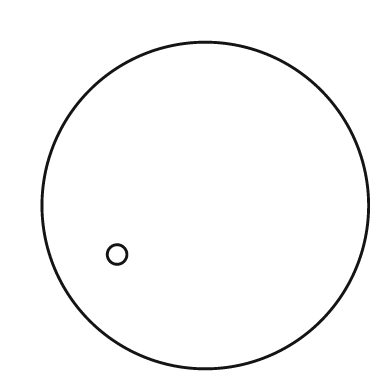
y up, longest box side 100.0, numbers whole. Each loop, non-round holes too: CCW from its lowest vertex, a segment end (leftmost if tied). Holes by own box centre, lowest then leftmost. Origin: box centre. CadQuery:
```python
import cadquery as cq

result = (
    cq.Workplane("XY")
    .moveTo(0.0, 0.0)
    .circle(50.0)
    .moveTo(-27.0, -15.0)
    .circle(3.0)
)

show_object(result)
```